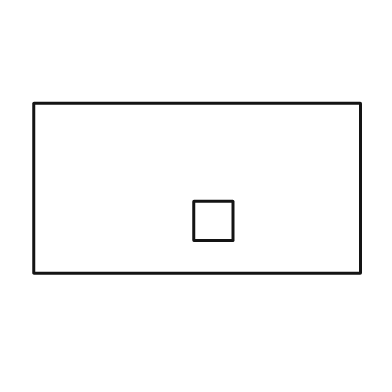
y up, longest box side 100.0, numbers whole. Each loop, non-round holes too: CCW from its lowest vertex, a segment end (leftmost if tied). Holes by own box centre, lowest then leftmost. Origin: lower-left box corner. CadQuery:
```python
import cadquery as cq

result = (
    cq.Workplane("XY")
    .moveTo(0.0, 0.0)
    .lineTo(100.0, 0.0)
    .lineTo(100.0, 52.0)
    .lineTo(0.0, 52.0)
    .close()
    .moveTo(49.0, 10.0)
    .lineTo(61.0, 10.0)
    .lineTo(61.0, 22.0)
    .lineTo(49.0, 22.0)
    .close()
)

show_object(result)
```